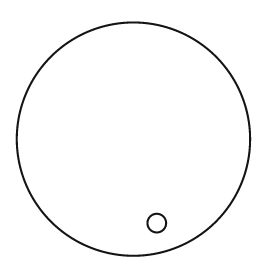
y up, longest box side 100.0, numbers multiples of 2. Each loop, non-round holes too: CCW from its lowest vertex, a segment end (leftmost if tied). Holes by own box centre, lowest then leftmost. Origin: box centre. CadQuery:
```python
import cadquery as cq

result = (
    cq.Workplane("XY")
    .moveTo(0.0, 0.0)
    .circle(50.0)
    .moveTo(10.0, -36.0)
    .circle(4.0)
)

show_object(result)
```